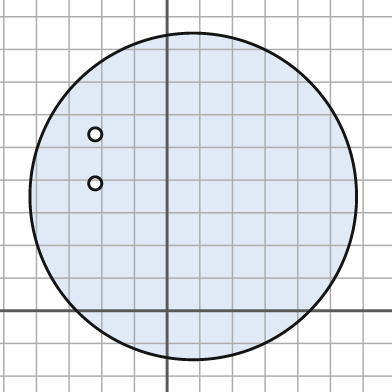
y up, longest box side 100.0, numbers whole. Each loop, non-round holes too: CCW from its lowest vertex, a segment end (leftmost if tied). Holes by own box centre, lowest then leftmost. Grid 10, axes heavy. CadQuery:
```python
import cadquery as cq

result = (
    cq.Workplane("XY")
    .moveTo(8.0, 35.0)
    .circle(50.0)
    .moveTo(-22.0, 39.0)
    .circle(2.0)
    .moveTo(-22.0, 54.0)
    .circle(2.0)
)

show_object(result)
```